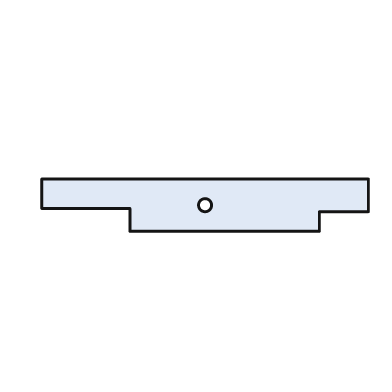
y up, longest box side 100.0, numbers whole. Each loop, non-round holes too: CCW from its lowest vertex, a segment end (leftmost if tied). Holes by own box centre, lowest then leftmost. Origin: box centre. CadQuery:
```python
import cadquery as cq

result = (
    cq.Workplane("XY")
    .moveTo(-23.0, -8.0)
    .lineTo(35.0, -8.0)
    .lineTo(35.0, -2.0)
    .lineTo(50.0, -2.0)
    .lineTo(50.0, 8.0)
    .lineTo(-50.0, 8.0)
    .lineTo(-50.0, -1.0)
    .lineTo(-23.0, -1.0)
    .close()
    .moveTo(0.0, 0.0)
    .circle(2.0)
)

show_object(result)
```